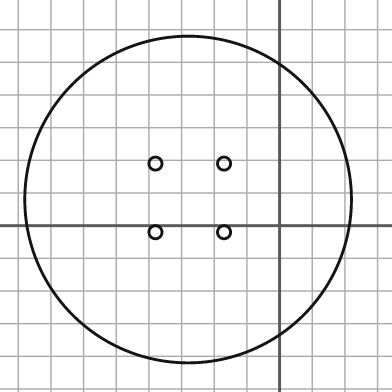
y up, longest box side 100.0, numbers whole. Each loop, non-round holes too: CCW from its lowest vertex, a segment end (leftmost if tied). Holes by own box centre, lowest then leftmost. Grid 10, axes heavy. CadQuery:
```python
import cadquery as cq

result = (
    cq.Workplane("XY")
    .moveTo(-28.0, 8.0)
    .circle(50.0)
    .moveTo(-38.0, -2.0)
    .circle(2.0)
    .moveTo(-17.0, -2.0)
    .circle(2.0)
    .moveTo(-38.0, 19.0)
    .circle(2.0)
    .moveTo(-17.0, 19.0)
    .circle(2.0)
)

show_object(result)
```